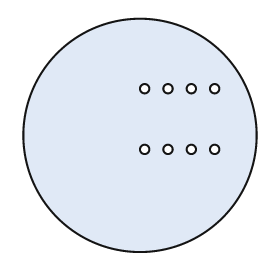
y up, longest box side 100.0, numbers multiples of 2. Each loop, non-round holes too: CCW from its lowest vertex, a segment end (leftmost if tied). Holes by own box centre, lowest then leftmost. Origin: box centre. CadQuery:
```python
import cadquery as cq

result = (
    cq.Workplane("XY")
    .moveTo(0.0, 0.0)
    .circle(50.0)
    .moveTo(2.0, -6.0)
    .circle(2.0)
    .moveTo(12.0, -6.0)
    .circle(2.0)
    .moveTo(22.0, -6.0)
    .circle(2.0)
    .moveTo(32.0, -6.0)
    .circle(2.0)
    .moveTo(2.0, 20.0)
    .circle(2.0)
    .moveTo(12.0, 20.0)
    .circle(2.0)
    .moveTo(22.0, 20.0)
    .circle(2.0)
    .moveTo(32.0, 20.0)
    .circle(2.0)
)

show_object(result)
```